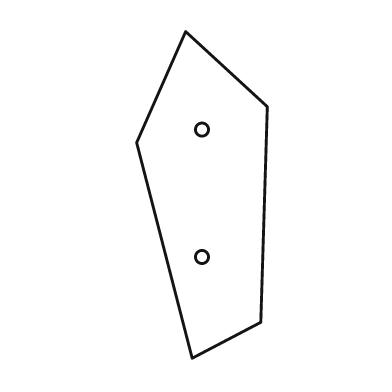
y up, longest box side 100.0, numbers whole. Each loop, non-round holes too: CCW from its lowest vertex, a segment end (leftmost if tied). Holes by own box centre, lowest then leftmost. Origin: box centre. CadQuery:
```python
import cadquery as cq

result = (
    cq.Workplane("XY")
    .moveTo(-3.0, -50.0)
    .lineTo(18.0, -39.0)
    .lineTo(20.0, 27.0)
    .lineTo(-5.0, 50.0)
    .lineTo(-20.0, 16.0)
    .close()
    .moveTo(0.0, -19.0)
    .circle(2.0)
    .moveTo(0.0, 20.0)
    .circle(2.0)
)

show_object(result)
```